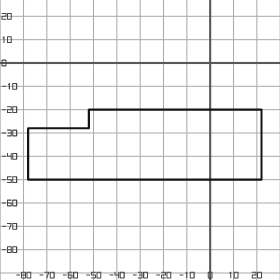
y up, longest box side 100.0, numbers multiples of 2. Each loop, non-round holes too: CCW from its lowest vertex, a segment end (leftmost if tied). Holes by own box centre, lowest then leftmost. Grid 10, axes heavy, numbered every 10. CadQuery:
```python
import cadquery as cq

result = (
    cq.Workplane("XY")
    .moveTo(-78.0, -50.0)
    .lineTo(22.0, -50.0)
    .lineTo(22.0, -20.0)
    .lineTo(-52.0, -20.0)
    .lineTo(-52.0, -28.0)
    .lineTo(-78.0, -28.0)
    .close()
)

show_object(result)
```